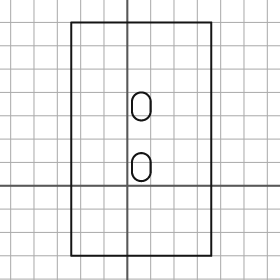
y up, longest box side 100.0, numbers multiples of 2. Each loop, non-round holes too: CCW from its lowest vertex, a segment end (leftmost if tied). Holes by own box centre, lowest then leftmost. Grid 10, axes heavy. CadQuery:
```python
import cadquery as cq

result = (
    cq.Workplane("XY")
    .moveTo(-24.0, -30.0)
    .lineTo(36.0, -30.0)
    .lineTo(36.0, 70.0)
    .lineTo(-24.0, 70.0)
    .close()
    .moveTo(2.0, 6.0)
    .threePointArc((6.0, 2.0), (10.0, 6.0))
    .lineTo(10.0, 10.0)
    .threePointArc((6.0, 14.0), (2.0, 10.0))
    .close()
    .moveTo(2.0, 32.0)
    .threePointArc((6.0, 28.0), (10.0, 32.0))
    .lineTo(10.0, 36.0)
    .threePointArc((6.0, 40.0), (2.0, 36.0))
    .close()
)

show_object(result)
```